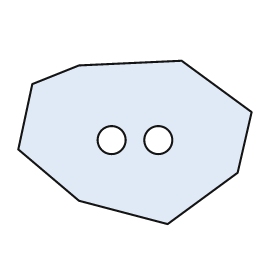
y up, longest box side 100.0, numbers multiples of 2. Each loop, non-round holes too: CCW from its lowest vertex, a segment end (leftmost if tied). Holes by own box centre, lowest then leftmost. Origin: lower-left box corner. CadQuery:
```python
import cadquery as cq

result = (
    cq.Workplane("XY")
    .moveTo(64.0, 0.0)
    .lineTo(94.0, 22.0)
    .lineTo(100.0, 48.0)
    .lineTo(70.0, 70.0)
    .lineTo(26.0, 68.0)
    .lineTo(6.0, 60.0)
    .lineTo(0.0, 32.0)
    .lineTo(26.0, 10.0)
    .close()
    .moveTo(40.0, 36.0)
    .circle(6.0)
    .moveTo(60.0, 36.0)
    .circle(6.0)
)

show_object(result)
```